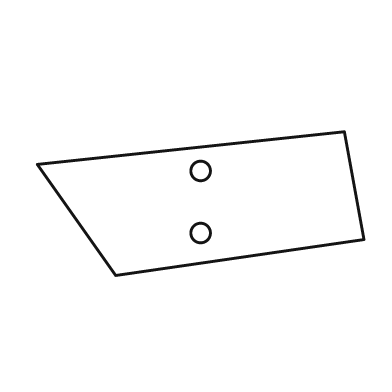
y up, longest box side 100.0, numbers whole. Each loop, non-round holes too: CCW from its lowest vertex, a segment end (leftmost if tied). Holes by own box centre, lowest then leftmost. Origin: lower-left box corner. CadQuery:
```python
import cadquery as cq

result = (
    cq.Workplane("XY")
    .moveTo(24.0, 0.0)
    .lineTo(100.0, 11.0)
    .lineTo(94.0, 44.0)
    .lineTo(0.0, 34.0)
    .close()
    .moveTo(50.0, 13.0)
    .circle(3.0)
    .moveTo(50.0, 32.0)
    .circle(3.0)
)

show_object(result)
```